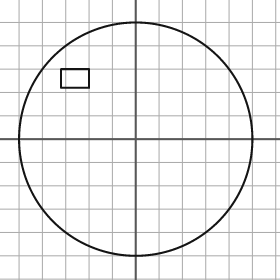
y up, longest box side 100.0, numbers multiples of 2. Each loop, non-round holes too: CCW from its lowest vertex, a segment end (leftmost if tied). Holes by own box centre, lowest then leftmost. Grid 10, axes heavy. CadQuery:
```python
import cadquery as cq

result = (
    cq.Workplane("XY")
    .moveTo(0.0, 0.0)
    .circle(50.0)
    .moveTo(-32.0, 22.0)
    .lineTo(-20.0, 22.0)
    .lineTo(-20.0, 30.0)
    .lineTo(-32.0, 30.0)
    .close()
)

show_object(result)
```